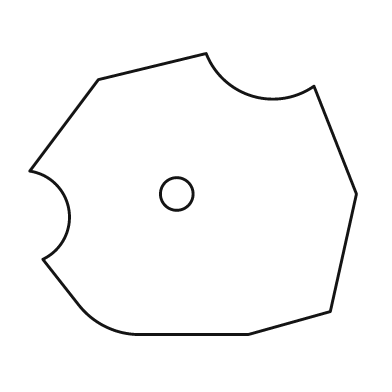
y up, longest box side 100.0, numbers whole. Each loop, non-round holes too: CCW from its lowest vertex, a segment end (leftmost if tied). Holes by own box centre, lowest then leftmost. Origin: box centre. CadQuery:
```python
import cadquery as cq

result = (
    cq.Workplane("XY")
    .moveTo(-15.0, -43.0)
    .lineTo(17.0, -43.0)
    .lineTo(42.0, -36.0)
    .lineTo(50.0, 0.0)
    .lineTo(37.0, 33.0)
    .threePointArc((18.0, 30.0), (4.0, 43.0))
    .lineTo(-29.0, 35.0)
    .lineTo(-50.0, 7.0)
    .threePointArc((-38.0, -5.0), (-46.0, -20.0))
    .lineTo(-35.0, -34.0)
    .threePointArc((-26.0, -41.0), (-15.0, -43.0))
    .close()
    .moveTo(-5.0, 0.0)
    .circle(5.0)
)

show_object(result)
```